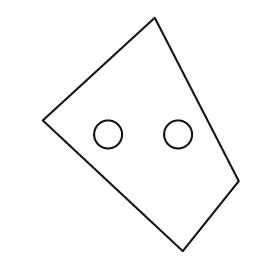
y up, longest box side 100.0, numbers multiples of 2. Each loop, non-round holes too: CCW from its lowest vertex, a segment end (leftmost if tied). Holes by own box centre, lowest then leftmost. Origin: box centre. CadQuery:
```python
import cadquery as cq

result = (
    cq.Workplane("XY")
    .moveTo(18.0, -50.0)
    .lineTo(42.0, -20.0)
    .lineTo(6.0, 50.0)
    .lineTo(-42.0, 6.0)
    .close()
    .moveTo(-14.0, 0.0)
    .circle(6.0)
    .moveTo(16.0, 0.0)
    .circle(6.0)
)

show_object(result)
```